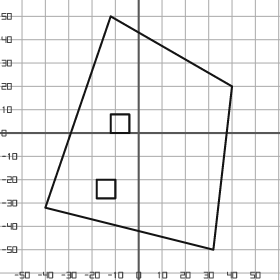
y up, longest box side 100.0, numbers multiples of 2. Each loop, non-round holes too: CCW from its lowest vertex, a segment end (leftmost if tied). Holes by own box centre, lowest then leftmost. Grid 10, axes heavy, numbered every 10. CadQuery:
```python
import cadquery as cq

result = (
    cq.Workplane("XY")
    .moveTo(32.0, -50.0)
    .lineTo(40.0, 20.0)
    .lineTo(-12.0, 50.0)
    .lineTo(-40.0, -32.0)
    .close()
    .moveTo(-18.0, -28.0)
    .lineTo(-10.0, -28.0)
    .lineTo(-10.0, -20.0)
    .lineTo(-18.0, -20.0)
    .close()
    .moveTo(-12.0, 0.0)
    .lineTo(-4.0, 0.0)
    .lineTo(-4.0, 8.0)
    .lineTo(-12.0, 8.0)
    .close()
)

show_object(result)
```